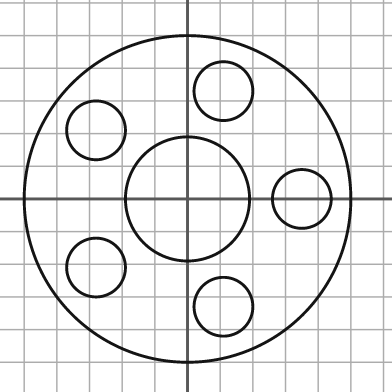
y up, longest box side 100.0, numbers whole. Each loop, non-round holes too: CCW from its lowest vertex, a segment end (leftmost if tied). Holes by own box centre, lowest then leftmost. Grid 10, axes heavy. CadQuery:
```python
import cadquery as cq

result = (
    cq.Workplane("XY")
    .moveTo(0.0, 0.0)
    .circle(50.0)
    .moveTo(11.0, -33.0)
    .circle(9.0)
    .moveTo(-28.0, -21.0)
    .circle(9.0)
    .moveTo(0.0, 0.0)
    .circle(19.0)
    .moveTo(35.0, 0.0)
    .circle(9.0)
    .moveTo(-28.0, 21.0)
    .circle(9.0)
    .moveTo(11.0, 33.0)
    .circle(9.0)
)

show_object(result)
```